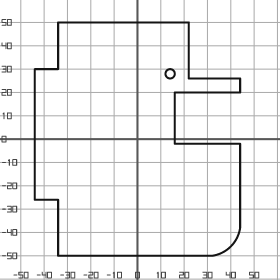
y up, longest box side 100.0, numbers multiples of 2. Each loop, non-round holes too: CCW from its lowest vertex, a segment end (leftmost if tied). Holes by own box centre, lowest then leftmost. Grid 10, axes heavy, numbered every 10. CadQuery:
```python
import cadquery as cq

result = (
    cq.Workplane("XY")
    .moveTo(-34.0, -50.0)
    .lineTo(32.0, -50.0)
    .threePointArc((40.0, -46.0), (44.0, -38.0))
    .lineTo(44.0, -2.0)
    .lineTo(16.0, -2.0)
    .lineTo(16.0, 20.0)
    .lineTo(44.0, 20.0)
    .lineTo(44.0, 26.0)
    .lineTo(22.0, 26.0)
    .lineTo(22.0, 50.0)
    .lineTo(-34.0, 50.0)
    .lineTo(-34.0, 30.0)
    .lineTo(-44.0, 30.0)
    .lineTo(-44.0, -26.0)
    .lineTo(-34.0, -26.0)
    .close()
    .moveTo(14.0, 28.0)
    .circle(2.0)
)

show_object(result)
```